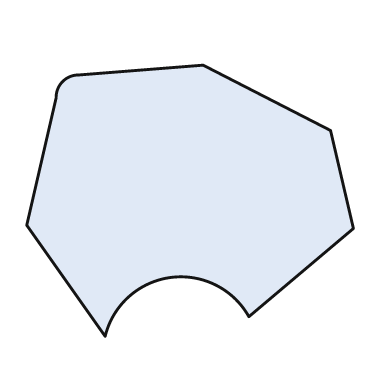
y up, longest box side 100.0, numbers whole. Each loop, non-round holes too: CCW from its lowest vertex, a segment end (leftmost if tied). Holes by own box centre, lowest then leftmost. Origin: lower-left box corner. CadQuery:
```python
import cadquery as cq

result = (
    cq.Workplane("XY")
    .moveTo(24.0, 0.0)
    .threePointArc((44.0, 18.0), (68.0, 6.0))
    .lineTo(100.0, 33.0)
    .lineTo(93.0, 63.0)
    .lineTo(54.0, 83.0)
    .lineTo(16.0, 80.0)
    .threePointArc((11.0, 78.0), (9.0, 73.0))
    .lineTo(0.0, 34.0)
    .close()
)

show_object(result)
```